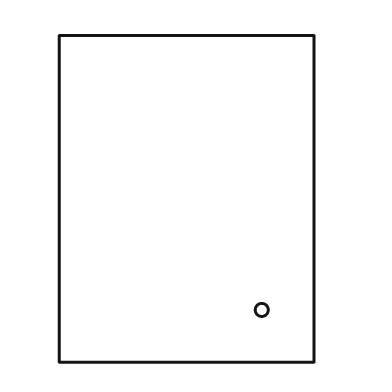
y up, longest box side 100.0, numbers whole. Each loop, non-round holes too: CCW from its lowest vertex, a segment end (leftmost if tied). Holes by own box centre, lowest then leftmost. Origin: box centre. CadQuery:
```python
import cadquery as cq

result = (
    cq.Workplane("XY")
    .moveTo(-39.0, -50.0)
    .lineTo(39.0, -50.0)
    .lineTo(39.0, 50.0)
    .lineTo(-39.0, 50.0)
    .close()
    .moveTo(23.0, -34.0)
    .circle(2.0)
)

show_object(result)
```